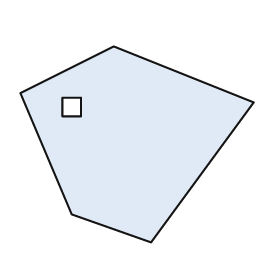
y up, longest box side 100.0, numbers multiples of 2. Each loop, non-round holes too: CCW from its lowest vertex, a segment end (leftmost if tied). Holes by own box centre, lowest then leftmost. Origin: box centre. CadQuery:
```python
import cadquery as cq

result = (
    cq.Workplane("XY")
    .moveTo(6.0, -42.0)
    .lineTo(50.0, 18.0)
    .lineTo(-10.0, 42.0)
    .lineTo(-50.0, 22.0)
    .lineTo(-28.0, -30.0)
    .close()
    .moveTo(-32.0, 12.0)
    .lineTo(-24.0, 12.0)
    .lineTo(-24.0, 20.0)
    .lineTo(-32.0, 20.0)
    .close()
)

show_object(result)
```